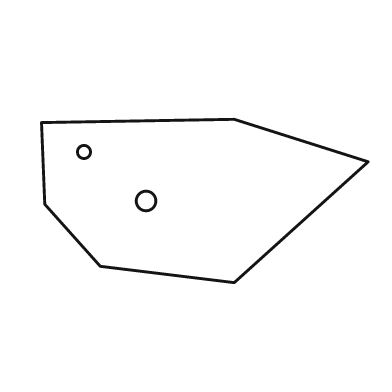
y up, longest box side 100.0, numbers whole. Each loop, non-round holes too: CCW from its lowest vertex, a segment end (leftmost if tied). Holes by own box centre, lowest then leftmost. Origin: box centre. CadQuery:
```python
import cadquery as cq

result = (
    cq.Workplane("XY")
    .moveTo(9.0, -25.0)
    .lineTo(50.0, 12.0)
    .lineTo(9.0, 25.0)
    .lineTo(-50.0, 24.0)
    .lineTo(-49.0, -1.0)
    .lineTo(-32.0, -20.0)
    .close()
    .moveTo(-18.0, 0.0)
    .circle(3.0)
    .moveTo(-37.0, 15.0)
    .circle(2.0)
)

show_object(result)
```